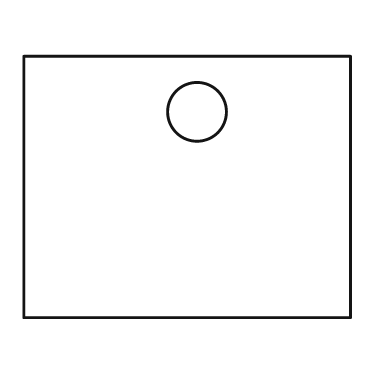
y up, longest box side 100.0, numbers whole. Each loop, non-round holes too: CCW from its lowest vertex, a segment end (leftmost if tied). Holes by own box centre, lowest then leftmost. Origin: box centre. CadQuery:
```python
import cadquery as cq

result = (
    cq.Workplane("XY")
    .moveTo(-50.0, -40.0)
    .lineTo(50.0, -40.0)
    .lineTo(50.0, 40.0)
    .lineTo(-50.0, 40.0)
    .close()
    .moveTo(3.0, 23.0)
    .circle(9.0)
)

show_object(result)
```